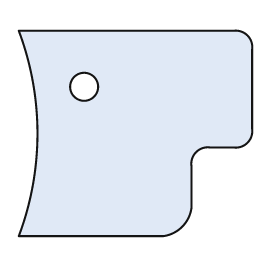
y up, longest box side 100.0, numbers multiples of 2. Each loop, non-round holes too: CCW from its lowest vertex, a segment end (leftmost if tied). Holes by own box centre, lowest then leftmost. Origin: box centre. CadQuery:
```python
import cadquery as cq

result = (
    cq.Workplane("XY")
    .moveTo(-50.0, -44.0)
    .lineTo(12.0, -44.0)
    .threePointArc((20.0, -40.0), (24.0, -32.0))
    .lineTo(24.0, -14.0)
    .threePointArc((26.0, -8.0), (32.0, -6.0))
    .lineTo(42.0, -6.0)
    .threePointArc((48.0, -4.0), (50.0, 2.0))
    .lineTo(50.0, 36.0)
    .threePointArc((48.0, 42.0), (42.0, 44.0))
    .lineTo(-50.0, 44.0)
    .threePointArc((-42.0, 0.0), (-50.0, -44.0))
    .close()
    .moveTo(-22.0, 20.0)
    .circle(6.0)
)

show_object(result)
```